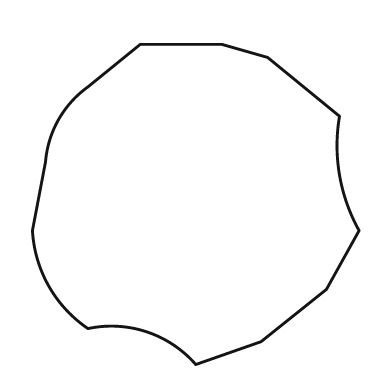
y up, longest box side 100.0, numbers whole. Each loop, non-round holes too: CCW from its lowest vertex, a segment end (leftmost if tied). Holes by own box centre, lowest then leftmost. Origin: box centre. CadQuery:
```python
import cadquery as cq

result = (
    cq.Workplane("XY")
    .moveTo(0.0, -49.0)
    .lineTo(20.0, -42.0)
    .lineTo(40.0, -26.0)
    .lineTo(50.0, -8.0)
    .threePointArc((44.0, 9.0), (44.0, 27.0))
    .lineTo(22.0, 45.0)
    .lineTo(8.0, 49.0)
    .lineTo(-17.0, 49.0)
    .lineTo(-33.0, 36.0)
    .threePointArc((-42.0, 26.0), (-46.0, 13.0))
    .lineTo(-50.0, -8.0)
    .threePointArc((-45.0, -25.0), (-33.0, -38.0))
    .threePointArc((-15.0, -39.0), (0.0, -49.0))
    .close()
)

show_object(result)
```